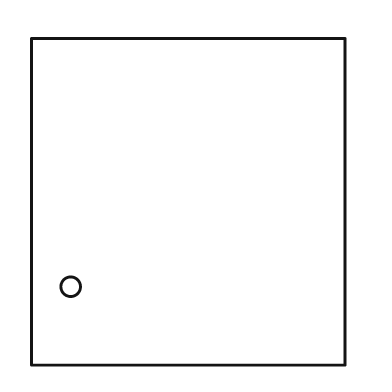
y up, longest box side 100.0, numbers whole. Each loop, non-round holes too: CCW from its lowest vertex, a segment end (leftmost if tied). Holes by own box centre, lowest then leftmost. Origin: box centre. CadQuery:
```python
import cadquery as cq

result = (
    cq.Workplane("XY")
    .moveTo(-48.0, -50.0)
    .lineTo(48.0, -50.0)
    .lineTo(48.0, 50.0)
    .lineTo(-48.0, 50.0)
    .close()
    .moveTo(-36.0, -26.0)
    .circle(3.0)
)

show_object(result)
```